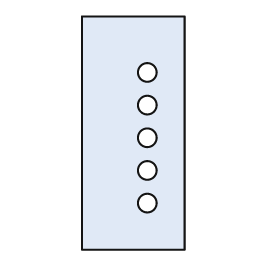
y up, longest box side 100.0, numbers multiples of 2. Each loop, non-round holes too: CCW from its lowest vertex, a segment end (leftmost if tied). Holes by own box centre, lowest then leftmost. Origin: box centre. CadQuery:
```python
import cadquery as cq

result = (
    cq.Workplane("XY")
    .moveTo(-22.0, -50.0)
    .lineTo(22.0, -50.0)
    .lineTo(22.0, 50.0)
    .lineTo(-22.0, 50.0)
    .close()
    .moveTo(6.0, -30.0)
    .circle(4.0)
    .moveTo(6.0, -16.0)
    .circle(4.0)
    .moveTo(6.0, -2.0)
    .circle(4.0)
    .moveTo(6.0, 12.0)
    .circle(4.0)
    .moveTo(6.0, 26.0)
    .circle(4.0)
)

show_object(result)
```